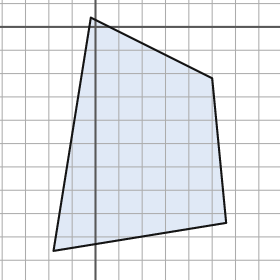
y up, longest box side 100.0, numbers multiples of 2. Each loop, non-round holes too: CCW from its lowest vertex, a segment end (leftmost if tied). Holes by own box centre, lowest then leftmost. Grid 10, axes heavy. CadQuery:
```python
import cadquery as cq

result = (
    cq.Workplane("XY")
    .moveTo(-18.0, -96.0)
    .lineTo(56.0, -84.0)
    .lineTo(50.0, -22.0)
    .lineTo(-2.0, 4.0)
    .close()
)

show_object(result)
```